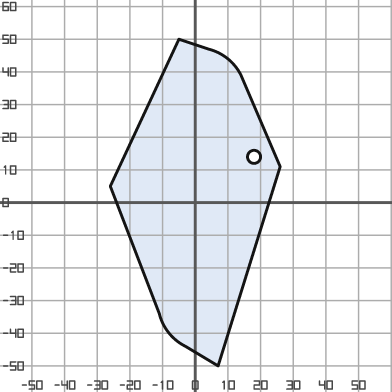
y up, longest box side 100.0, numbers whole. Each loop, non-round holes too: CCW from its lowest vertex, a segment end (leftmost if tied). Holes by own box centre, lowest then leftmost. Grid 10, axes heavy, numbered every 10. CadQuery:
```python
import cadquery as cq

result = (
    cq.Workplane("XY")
    .moveTo(7.0, -50.0)
    .lineTo(26.0, 11.0)
    .lineTo(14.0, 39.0)
    .threePointArc((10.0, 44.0), (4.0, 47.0))
    .lineTo(-5.0, 50.0)
    .lineTo(-26.0, 5.0)
    .lineTo(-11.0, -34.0)
    .threePointArc((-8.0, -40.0), (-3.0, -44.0))
    .close()
    .moveTo(18.0, 14.0)
    .circle(2.0)
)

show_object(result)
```